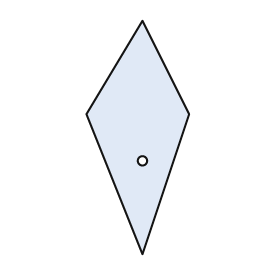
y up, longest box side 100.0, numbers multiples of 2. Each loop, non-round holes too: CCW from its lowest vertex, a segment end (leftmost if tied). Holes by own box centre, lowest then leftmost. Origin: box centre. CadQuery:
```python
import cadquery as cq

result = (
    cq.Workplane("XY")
    .moveTo(2.0, -50.0)
    .lineTo(22.0, 10.0)
    .lineTo(2.0, 50.0)
    .lineTo(-22.0, 10.0)
    .close()
    .moveTo(2.0, -10.0)
    .circle(2.0)
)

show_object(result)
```